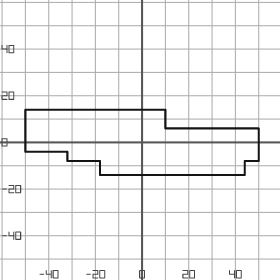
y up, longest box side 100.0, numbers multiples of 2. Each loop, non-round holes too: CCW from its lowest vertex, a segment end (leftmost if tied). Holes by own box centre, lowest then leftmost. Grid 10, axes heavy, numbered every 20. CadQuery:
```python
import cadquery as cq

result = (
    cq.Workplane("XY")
    .moveTo(-18.0, -14.0)
    .lineTo(44.0, -14.0)
    .lineTo(44.0, -8.0)
    .lineTo(50.0, -8.0)
    .lineTo(50.0, 6.0)
    .lineTo(10.0, 6.0)
    .lineTo(10.0, 14.0)
    .lineTo(-50.0, 14.0)
    .lineTo(-50.0, -4.0)
    .lineTo(-32.0, -4.0)
    .lineTo(-32.0, -8.0)
    .lineTo(-18.0, -8.0)
    .close()
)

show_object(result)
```